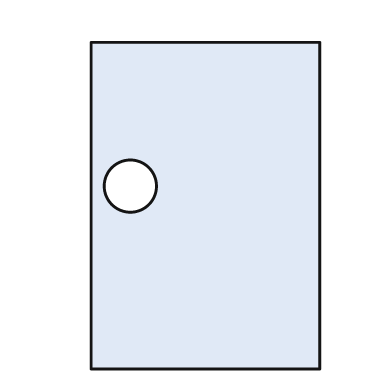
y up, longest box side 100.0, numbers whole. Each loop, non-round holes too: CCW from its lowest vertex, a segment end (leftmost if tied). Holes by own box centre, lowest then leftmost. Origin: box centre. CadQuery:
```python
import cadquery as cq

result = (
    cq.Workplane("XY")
    .moveTo(-35.0, -50.0)
    .lineTo(35.0, -50.0)
    .lineTo(35.0, 50.0)
    .lineTo(-35.0, 50.0)
    .close()
    .moveTo(-23.0, 6.0)
    .circle(8.0)
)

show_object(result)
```